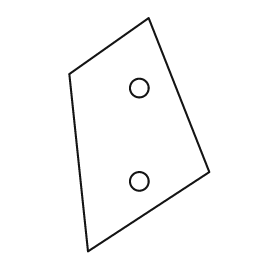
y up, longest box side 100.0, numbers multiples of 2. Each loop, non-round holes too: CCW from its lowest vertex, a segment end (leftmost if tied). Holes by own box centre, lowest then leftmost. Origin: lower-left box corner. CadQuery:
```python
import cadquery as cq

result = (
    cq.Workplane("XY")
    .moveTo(8.0, 0.0)
    .lineTo(60.0, 34.0)
    .lineTo(34.0, 100.0)
    .lineTo(0.0, 76.0)
    .close()
    .moveTo(30.0, 30.0)
    .circle(4.0)
    .moveTo(30.0, 70.0)
    .circle(4.0)
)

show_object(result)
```